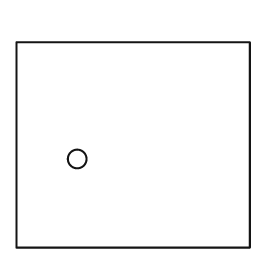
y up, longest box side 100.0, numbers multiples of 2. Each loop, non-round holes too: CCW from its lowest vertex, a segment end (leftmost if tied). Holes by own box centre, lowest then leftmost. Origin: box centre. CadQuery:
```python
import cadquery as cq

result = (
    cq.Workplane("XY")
    .moveTo(-50.0, -44.0)
    .lineTo(50.0, -44.0)
    .lineTo(50.0, 44.0)
    .lineTo(-50.0, 44.0)
    .close()
    .moveTo(-24.0, -6.0)
    .circle(4.0)
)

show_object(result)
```